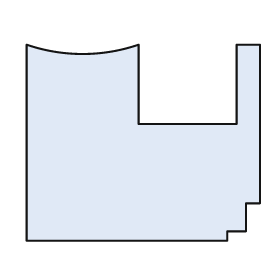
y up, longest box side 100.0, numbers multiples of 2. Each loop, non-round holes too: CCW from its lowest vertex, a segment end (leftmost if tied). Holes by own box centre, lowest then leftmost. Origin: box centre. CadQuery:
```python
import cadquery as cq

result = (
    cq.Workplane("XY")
    .moveTo(-50.0, -42.0)
    .lineTo(36.0, -42.0)
    .lineTo(36.0, -38.0)
    .lineTo(44.0, -38.0)
    .lineTo(44.0, -26.0)
    .lineTo(50.0, -26.0)
    .lineTo(50.0, 42.0)
    .lineTo(40.0, 42.0)
    .lineTo(40.0, 8.0)
    .lineTo(-2.0, 8.0)
    .lineTo(-2.0, 42.0)
    .threePointArc((-26.0, 38.0), (-50.0, 42.0))
    .close()
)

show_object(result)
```